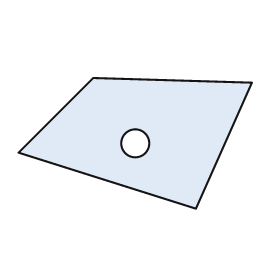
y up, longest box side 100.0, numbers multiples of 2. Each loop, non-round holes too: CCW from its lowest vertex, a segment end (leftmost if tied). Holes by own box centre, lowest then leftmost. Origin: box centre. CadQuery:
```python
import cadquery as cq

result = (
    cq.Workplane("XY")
    .moveTo(26.0, -28.0)
    .lineTo(50.0, 26.0)
    .lineTo(-18.0, 28.0)
    .lineTo(-50.0, -4.0)
    .close()
    .moveTo(0.0, 0.0)
    .circle(6.0)
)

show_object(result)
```